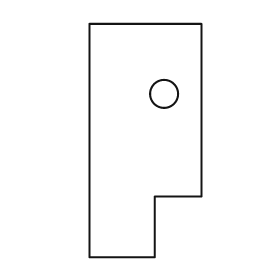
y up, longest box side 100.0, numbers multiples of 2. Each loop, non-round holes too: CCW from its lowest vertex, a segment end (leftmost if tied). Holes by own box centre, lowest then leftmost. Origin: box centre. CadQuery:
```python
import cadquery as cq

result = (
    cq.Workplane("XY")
    .moveTo(-24.0, -50.0)
    .lineTo(4.0, -50.0)
    .lineTo(4.0, -24.0)
    .lineTo(24.0, -24.0)
    .lineTo(24.0, 50.0)
    .lineTo(-24.0, 50.0)
    .close()
    .moveTo(8.0, 20.0)
    .circle(6.0)
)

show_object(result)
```